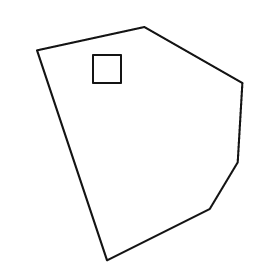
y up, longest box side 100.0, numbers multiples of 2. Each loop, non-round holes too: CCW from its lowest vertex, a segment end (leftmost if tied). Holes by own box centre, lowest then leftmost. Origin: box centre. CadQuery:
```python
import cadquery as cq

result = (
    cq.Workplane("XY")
    .moveTo(-14.0, -50.0)
    .lineTo(30.0, -28.0)
    .lineTo(42.0, -8.0)
    .lineTo(44.0, 26.0)
    .lineTo(2.0, 50.0)
    .lineTo(-44.0, 40.0)
    .close()
    .moveTo(-20.0, 26.0)
    .lineTo(-8.0, 26.0)
    .lineTo(-8.0, 38.0)
    .lineTo(-20.0, 38.0)
    .close()
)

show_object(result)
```